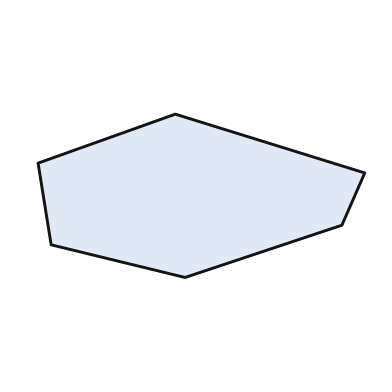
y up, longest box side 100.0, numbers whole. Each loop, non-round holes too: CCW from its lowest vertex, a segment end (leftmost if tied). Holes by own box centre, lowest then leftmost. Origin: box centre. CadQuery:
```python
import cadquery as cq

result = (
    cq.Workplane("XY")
    .moveTo(-5.0, -25.0)
    .lineTo(43.0, -9.0)
    .lineTo(50.0, 7.0)
    .lineTo(-8.0, 25.0)
    .lineTo(-50.0, 10.0)
    .lineTo(-46.0, -15.0)
    .close()
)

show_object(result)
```